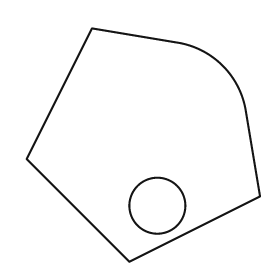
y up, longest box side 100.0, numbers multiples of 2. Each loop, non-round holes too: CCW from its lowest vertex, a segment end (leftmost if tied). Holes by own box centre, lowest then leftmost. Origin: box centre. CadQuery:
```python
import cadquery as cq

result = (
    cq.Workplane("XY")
    .moveTo(-6.0, -50.0)
    .lineTo(50.0, -22.0)
    .lineTo(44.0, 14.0)
    .threePointArc((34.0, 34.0), (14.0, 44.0))
    .lineTo(-22.0, 50.0)
    .lineTo(-50.0, -6.0)
    .close()
    .moveTo(6.0, -26.0)
    .circle(12.0)
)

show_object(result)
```